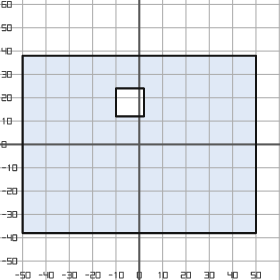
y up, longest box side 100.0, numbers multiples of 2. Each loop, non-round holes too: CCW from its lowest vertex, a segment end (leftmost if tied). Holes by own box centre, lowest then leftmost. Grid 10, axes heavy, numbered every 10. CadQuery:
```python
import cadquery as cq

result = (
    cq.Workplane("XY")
    .moveTo(-50.0, -38.0)
    .lineTo(50.0, -38.0)
    .lineTo(50.0, 38.0)
    .lineTo(-50.0, 38.0)
    .close()
    .moveTo(-10.0, 12.0)
    .lineTo(2.0, 12.0)
    .lineTo(2.0, 24.0)
    .lineTo(-10.0, 24.0)
    .close()
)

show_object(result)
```